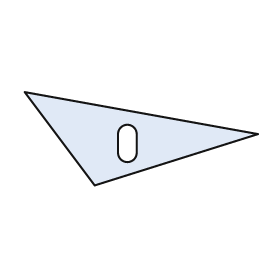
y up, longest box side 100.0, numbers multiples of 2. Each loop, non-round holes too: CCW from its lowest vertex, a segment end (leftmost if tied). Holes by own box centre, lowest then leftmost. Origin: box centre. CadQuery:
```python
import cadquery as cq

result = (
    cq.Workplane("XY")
    .moveTo(-20.0, -20.0)
    .lineTo(50.0, 2.0)
    .lineTo(-50.0, 20.0)
    .close()
    .moveTo(-10.0, -6.0)
    .threePointArc((-6.0, -10.0), (-2.0, -6.0))
    .lineTo(-2.0, 2.0)
    .threePointArc((-6.0, 6.0), (-10.0, 2.0))
    .close()
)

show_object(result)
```